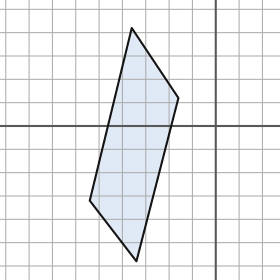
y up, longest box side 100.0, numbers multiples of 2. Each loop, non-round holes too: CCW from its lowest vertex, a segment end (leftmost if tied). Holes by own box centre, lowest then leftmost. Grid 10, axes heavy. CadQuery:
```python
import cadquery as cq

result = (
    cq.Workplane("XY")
    .moveTo(-34.0, -58.0)
    .lineTo(-16.0, 12.0)
    .lineTo(-36.0, 42.0)
    .lineTo(-54.0, -32.0)
    .close()
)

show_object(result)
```